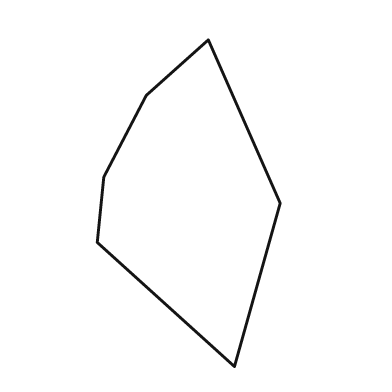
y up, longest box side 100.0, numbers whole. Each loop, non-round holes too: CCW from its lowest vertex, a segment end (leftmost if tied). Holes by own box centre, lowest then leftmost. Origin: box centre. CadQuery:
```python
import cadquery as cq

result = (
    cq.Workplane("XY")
    .moveTo(14.0, -50.0)
    .lineTo(28.0, 0.0)
    .lineTo(6.0, 50.0)
    .lineTo(-13.0, 33.0)
    .lineTo(-26.0, 8.0)
    .lineTo(-28.0, -12.0)
    .close()
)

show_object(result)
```